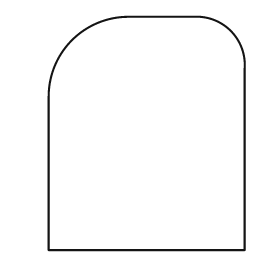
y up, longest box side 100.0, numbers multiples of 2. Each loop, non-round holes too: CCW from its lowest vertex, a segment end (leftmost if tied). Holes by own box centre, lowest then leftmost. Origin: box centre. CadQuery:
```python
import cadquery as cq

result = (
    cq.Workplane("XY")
    .moveTo(-42.0, -50.0)
    .lineTo(42.0, -50.0)
    .lineTo(42.0, 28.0)
    .threePointArc((36.0, 44.0), (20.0, 50.0))
    .lineTo(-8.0, 50.0)
    .threePointArc((-32.0, 40.0), (-42.0, 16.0))
    .close()
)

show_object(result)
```